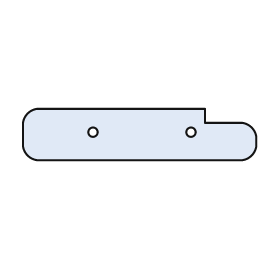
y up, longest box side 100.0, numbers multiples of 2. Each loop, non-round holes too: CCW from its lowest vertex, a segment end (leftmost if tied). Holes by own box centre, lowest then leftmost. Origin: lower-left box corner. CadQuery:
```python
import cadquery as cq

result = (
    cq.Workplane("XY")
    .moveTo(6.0, 0.0)
    .lineTo(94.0, 0.0)
    .threePointArc((98.0, 2.0), (100.0, 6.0))
    .lineTo(100.0, 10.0)
    .threePointArc((98.0, 14.0), (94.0, 16.0))
    .lineTo(78.0, 16.0)
    .lineTo(78.0, 22.0)
    .lineTo(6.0, 22.0)
    .threePointArc((2.0, 20.0), (0.0, 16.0))
    .lineTo(0.0, 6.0)
    .threePointArc((2.0, 2.0), (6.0, 0.0))
    .close()
    .moveTo(30.0, 12.0)
    .circle(2.0)
    .moveTo(72.0, 12.0)
    .circle(2.0)
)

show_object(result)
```